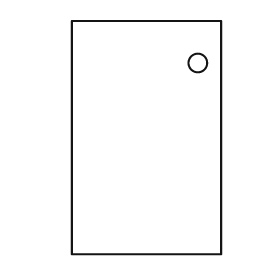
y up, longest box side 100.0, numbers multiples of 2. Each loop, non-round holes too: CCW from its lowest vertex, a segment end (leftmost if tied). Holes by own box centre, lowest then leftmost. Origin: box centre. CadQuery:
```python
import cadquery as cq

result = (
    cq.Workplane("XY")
    .moveTo(-32.0, -50.0)
    .lineTo(32.0, -50.0)
    .lineTo(32.0, 50.0)
    .lineTo(-32.0, 50.0)
    .close()
    .moveTo(22.0, 32.0)
    .circle(4.0)
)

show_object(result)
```